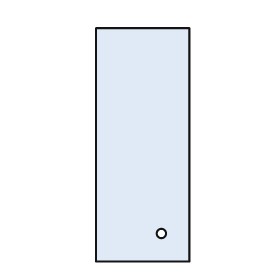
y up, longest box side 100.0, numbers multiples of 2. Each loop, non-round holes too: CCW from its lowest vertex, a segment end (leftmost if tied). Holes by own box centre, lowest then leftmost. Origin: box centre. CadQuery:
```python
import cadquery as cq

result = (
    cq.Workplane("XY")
    .moveTo(-20.0, -50.0)
    .lineTo(20.0, -50.0)
    .lineTo(20.0, 50.0)
    .lineTo(-20.0, 50.0)
    .close()
    .moveTo(8.0, -38.0)
    .circle(2.0)
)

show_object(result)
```